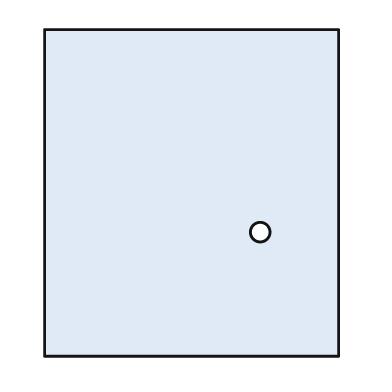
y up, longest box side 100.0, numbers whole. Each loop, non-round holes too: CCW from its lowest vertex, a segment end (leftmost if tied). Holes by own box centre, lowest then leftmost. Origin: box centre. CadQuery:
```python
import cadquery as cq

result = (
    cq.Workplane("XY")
    .moveTo(-45.0, -50.0)
    .lineTo(45.0, -50.0)
    .lineTo(45.0, 50.0)
    .lineTo(-45.0, 50.0)
    .close()
    .moveTo(21.0, -12.0)
    .circle(3.0)
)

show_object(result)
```